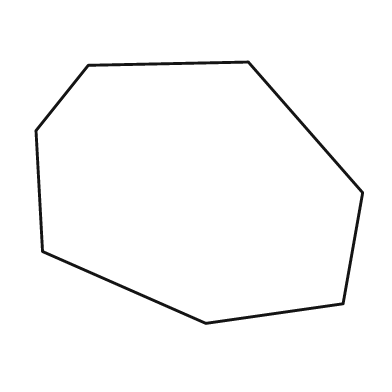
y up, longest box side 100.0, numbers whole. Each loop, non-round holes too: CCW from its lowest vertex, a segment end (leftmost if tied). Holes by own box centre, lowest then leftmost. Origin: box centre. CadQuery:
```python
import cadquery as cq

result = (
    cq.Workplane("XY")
    .moveTo(2.0, -40.0)
    .lineTo(44.0, -34.0)
    .lineTo(50.0, 0.0)
    .lineTo(15.0, 40.0)
    .lineTo(-34.0, 39.0)
    .lineTo(-50.0, 19.0)
    .lineTo(-48.0, -18.0)
    .close()
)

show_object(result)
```